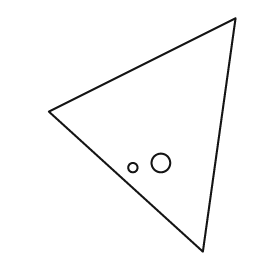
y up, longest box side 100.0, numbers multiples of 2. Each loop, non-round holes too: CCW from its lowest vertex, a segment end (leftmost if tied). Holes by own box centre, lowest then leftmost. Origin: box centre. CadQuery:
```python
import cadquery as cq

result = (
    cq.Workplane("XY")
    .moveTo(26.0, -50.0)
    .lineTo(40.0, 50.0)
    .lineTo(-40.0, 10.0)
    .close()
    .moveTo(-4.0, -14.0)
    .circle(2.0)
    .moveTo(8.0, -12.0)
    .circle(4.0)
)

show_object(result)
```